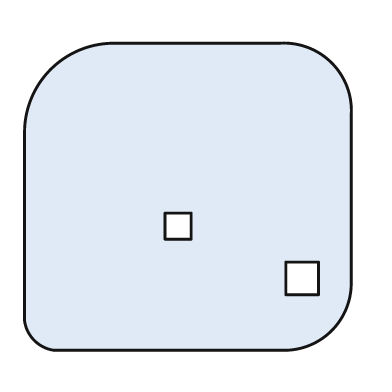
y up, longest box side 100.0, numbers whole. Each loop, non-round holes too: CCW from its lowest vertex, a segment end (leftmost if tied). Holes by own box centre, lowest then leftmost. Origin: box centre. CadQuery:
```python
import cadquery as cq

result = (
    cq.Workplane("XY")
    .moveTo(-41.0, -47.0)
    .lineTo(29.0, -47.0)
    .threePointArc((44.0, -41.0), (50.0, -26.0))
    .lineTo(50.0, 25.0)
    .threePointArc((44.0, 41.0), (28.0, 47.0))
    .lineTo(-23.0, 47.0)
    .threePointArc((-42.0, 39.0), (-50.0, 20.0))
    .lineTo(-50.0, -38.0)
    .threePointArc((-47.0, -44.0), (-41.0, -47.0))
    .close()
    .moveTo(30.0, -30.0)
    .lineTo(40.0, -30.0)
    .lineTo(40.0, -20.0)
    .lineTo(30.0, -20.0)
    .close()
    .moveTo(-7.0, -13.0)
    .lineTo(1.0, -13.0)
    .lineTo(1.0, -5.0)
    .lineTo(-7.0, -5.0)
    .close()
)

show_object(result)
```